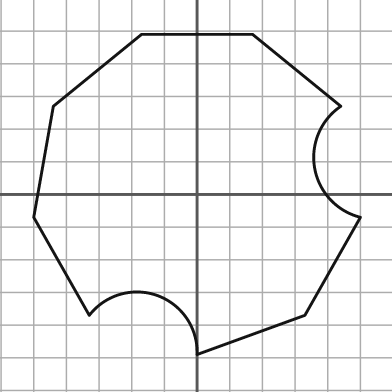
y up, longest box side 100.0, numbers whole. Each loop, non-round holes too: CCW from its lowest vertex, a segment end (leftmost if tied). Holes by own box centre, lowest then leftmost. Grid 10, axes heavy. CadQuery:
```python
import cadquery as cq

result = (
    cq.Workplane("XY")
    .moveTo(0.0, -49.0)
    .lineTo(33.0, -37.0)
    .lineTo(50.0, -7.0)
    .threePointArc((36.0, 8.0), (44.0, 27.0))
    .lineTo(17.0, 49.0)
    .lineTo(-17.0, 49.0)
    .lineTo(-44.0, 27.0)
    .lineTo(-50.0, -7.0)
    .lineTo(-33.0, -37.0)
    .threePointArc((-12.0, -31.0), (0.0, -49.0))
    .close()
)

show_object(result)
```